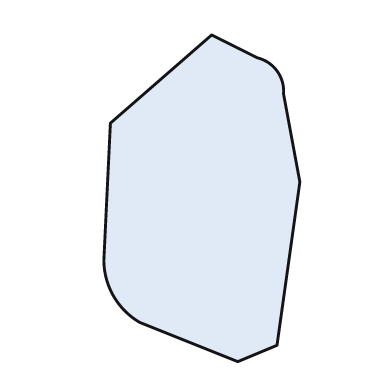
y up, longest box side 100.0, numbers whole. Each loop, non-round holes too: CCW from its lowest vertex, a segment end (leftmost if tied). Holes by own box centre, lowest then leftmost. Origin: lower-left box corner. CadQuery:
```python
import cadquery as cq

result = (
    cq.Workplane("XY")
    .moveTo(41.0, 0.0)
    .lineTo(53.0, 5.0)
    .lineTo(60.0, 55.0)
    .lineTo(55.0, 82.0)
    .threePointArc((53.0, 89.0), (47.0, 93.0))
    .lineTo(33.0, 100.0)
    .lineTo(2.0, 73.0)
    .lineTo(0.0, 31.0)
    .threePointArc((3.0, 20.0), (11.0, 12.0))
    .close()
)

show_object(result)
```